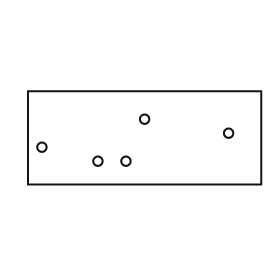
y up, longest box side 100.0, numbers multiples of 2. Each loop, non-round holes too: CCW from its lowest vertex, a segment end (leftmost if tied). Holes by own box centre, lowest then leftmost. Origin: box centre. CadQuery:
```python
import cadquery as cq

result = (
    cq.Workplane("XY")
    .moveTo(-50.0, -20.0)
    .lineTo(50.0, -20.0)
    .lineTo(50.0, 20.0)
    .lineTo(-50.0, 20.0)
    .close()
    .moveTo(-20.0, -10.0)
    .circle(2.0)
    .moveTo(-8.0, -10.0)
    .circle(2.0)
    .moveTo(-44.0, -4.0)
    .circle(2.0)
    .moveTo(36.0, 2.0)
    .circle(2.0)
    .moveTo(0.0, 8.0)
    .circle(2.0)
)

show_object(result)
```